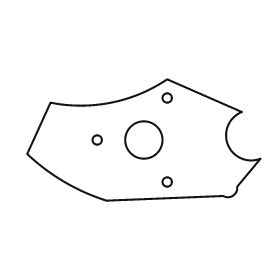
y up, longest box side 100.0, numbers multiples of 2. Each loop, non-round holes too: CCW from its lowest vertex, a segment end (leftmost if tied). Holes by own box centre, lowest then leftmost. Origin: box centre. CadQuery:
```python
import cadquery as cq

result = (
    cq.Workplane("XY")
    .moveTo(-16.0, -26.0)
    .lineTo(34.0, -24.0)
    .threePointArc((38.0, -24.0), (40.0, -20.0))
    .lineTo(50.0, -8.0)
    .threePointArc((36.0, -2.0), (42.0, 12.0))
    .lineTo(10.0, 26.0)
    .threePointArc((-14.0, 16.0), (-40.0, 16.0))
    .lineTo(-50.0, -6.0)
    .threePointArc((-34.0, -18.0), (-16.0, -26.0))
    .close()
    .moveTo(10.0, -18.0)
    .circle(2.0)
    .moveTo(-20.0, 0.0)
    .circle(2.0)
    .moveTo(0.0, 0.0)
    .circle(8.0)
    .moveTo(10.0, 18.0)
    .circle(2.0)
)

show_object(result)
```